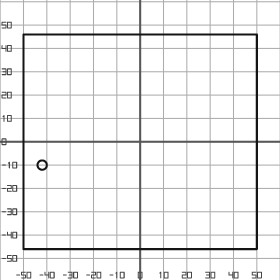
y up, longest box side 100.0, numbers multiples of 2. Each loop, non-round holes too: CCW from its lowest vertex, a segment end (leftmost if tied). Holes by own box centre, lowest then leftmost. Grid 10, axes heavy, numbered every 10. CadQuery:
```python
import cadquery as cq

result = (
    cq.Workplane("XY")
    .moveTo(-50.0, -46.0)
    .lineTo(50.0, -46.0)
    .lineTo(50.0, 46.0)
    .lineTo(-50.0, 46.0)
    .close()
    .moveTo(-42.0, -10.0)
    .circle(2.0)
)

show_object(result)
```